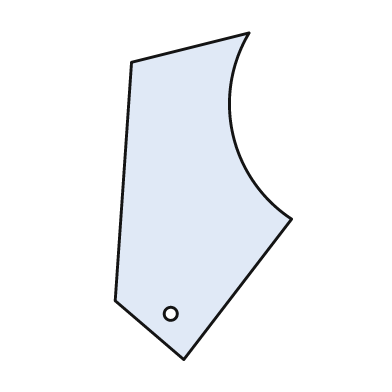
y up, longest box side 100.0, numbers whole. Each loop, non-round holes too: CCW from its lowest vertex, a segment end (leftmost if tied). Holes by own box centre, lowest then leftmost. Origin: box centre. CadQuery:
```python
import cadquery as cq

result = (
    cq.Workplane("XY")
    .moveTo(-6.0, -50.0)
    .lineTo(27.0, -7.0)
    .threePointArc((9.0, 19.0), (14.0, 50.0))
    .lineTo(-22.0, 41.0)
    .lineTo(-27.0, -32.0)
    .close()
    .moveTo(-10.0, -36.0)
    .circle(2.0)
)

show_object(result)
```